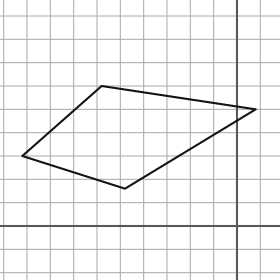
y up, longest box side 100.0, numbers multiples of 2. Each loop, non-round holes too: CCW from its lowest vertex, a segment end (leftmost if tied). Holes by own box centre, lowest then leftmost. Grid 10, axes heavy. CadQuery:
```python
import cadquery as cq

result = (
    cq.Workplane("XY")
    .moveTo(-48.0, 16.0)
    .lineTo(8.0, 50.0)
    .lineTo(-58.0, 60.0)
    .lineTo(-92.0, 30.0)
    .close()
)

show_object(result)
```